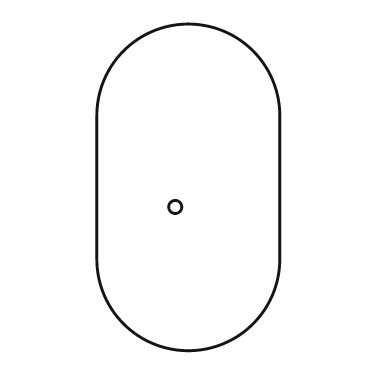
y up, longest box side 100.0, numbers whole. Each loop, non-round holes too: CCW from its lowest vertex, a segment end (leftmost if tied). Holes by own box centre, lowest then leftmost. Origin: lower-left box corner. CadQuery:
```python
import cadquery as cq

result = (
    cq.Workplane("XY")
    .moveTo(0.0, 28.0)
    .threePointArc((28.0, 0.0), (56.0, 28.0))
    .lineTo(56.0, 72.0)
    .threePointArc((28.0, 100.0), (0.0, 72.0))
    .close()
    .moveTo(24.0, 44.0)
    .circle(2.0)
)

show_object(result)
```